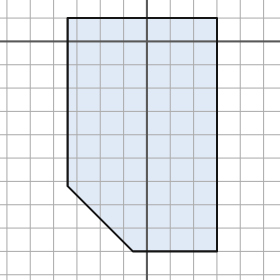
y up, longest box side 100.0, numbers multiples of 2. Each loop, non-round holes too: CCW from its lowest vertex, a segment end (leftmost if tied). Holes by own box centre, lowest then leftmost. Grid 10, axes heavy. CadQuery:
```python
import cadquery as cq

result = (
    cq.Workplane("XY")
    .moveTo(-6.0, -90.0)
    .lineTo(30.0, -90.0)
    .lineTo(30.0, 10.0)
    .lineTo(-34.0, 10.0)
    .lineTo(-34.0, -62.0)
    .close()
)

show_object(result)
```